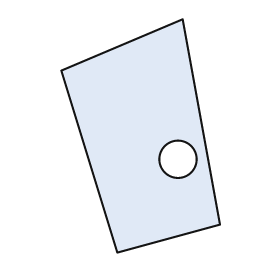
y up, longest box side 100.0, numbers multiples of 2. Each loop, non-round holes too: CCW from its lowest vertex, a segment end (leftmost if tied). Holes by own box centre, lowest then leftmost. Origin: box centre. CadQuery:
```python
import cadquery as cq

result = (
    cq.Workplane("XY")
    .moveTo(-10.0, -50.0)
    .lineTo(34.0, -38.0)
    .lineTo(18.0, 50.0)
    .lineTo(-34.0, 28.0)
    .close()
    .moveTo(16.0, -10.0)
    .circle(8.0)
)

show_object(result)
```